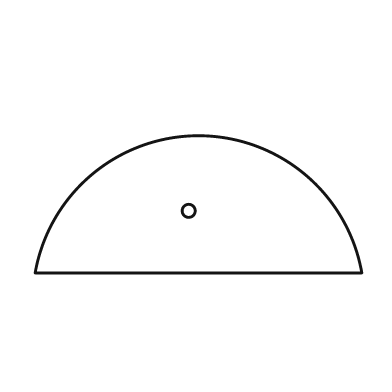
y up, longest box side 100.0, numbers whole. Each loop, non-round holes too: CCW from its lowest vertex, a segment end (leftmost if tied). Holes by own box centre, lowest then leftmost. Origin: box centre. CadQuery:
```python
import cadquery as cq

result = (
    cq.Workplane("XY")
    .moveTo(-50.0, -21.0)
    .lineTo(50.0, -21.0)
    .threePointArc((0.0, 21.0), (-50.0, -21.0))
    .close()
    .moveTo(-3.0, -2.0)
    .circle(2.0)
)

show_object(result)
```